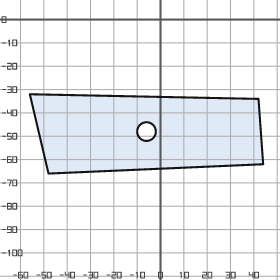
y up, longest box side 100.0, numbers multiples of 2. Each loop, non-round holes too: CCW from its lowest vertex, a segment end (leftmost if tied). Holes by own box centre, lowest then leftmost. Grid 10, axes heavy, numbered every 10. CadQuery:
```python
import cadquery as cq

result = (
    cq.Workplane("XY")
    .moveTo(-48.0, -66.0)
    .lineTo(44.0, -62.0)
    .lineTo(42.0, -34.0)
    .lineTo(-56.0, -32.0)
    .close()
    .moveTo(-6.0, -48.0)
    .circle(4.0)
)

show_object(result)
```